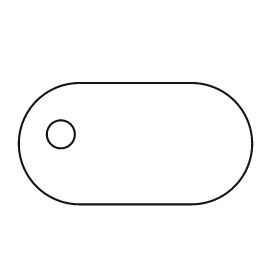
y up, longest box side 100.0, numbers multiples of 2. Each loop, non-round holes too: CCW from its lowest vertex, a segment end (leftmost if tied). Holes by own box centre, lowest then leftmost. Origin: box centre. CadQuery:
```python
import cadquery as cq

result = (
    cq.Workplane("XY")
    .moveTo(-24.0, -26.0)
    .lineTo(24.0, -26.0)
    .threePointArc((50.0, 0.0), (24.0, 26.0))
    .lineTo(-24.0, 26.0)
    .threePointArc((-50.0, 0.0), (-24.0, -26.0))
    .close()
    .moveTo(-32.0, 4.0)
    .circle(6.0)
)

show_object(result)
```